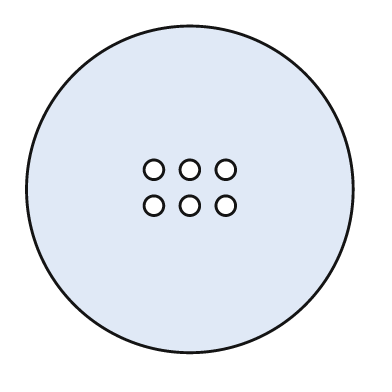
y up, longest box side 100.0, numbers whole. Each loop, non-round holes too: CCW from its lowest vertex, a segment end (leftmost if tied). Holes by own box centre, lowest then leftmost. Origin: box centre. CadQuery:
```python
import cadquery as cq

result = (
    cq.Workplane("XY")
    .moveTo(0.0, 0.0)
    .circle(50.0)
    .moveTo(-11.0, -5.0)
    .circle(3.0)
    .moveTo(0.0, -5.0)
    .circle(3.0)
    .moveTo(11.0, -5.0)
    .circle(3.0)
    .moveTo(-11.0, 6.0)
    .circle(3.0)
    .moveTo(0.0, 6.0)
    .circle(3.0)
    .moveTo(11.0, 6.0)
    .circle(3.0)
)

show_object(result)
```